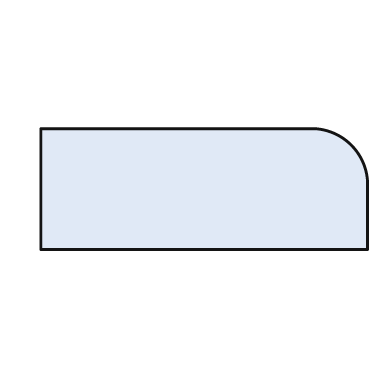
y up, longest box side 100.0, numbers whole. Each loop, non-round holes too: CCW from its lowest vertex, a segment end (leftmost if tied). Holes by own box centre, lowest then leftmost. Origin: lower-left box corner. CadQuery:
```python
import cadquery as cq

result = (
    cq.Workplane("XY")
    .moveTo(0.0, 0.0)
    .lineTo(100.0, 0.0)
    .lineTo(100.0, 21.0)
    .threePointArc((95.0, 32.0), (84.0, 37.0))
    .lineTo(0.0, 37.0)
    .close()
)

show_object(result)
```